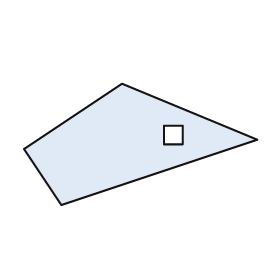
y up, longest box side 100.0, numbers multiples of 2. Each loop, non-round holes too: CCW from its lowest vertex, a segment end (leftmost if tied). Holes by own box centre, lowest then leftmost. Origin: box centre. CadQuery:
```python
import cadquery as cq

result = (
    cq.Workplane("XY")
    .moveTo(-34.0, -26.0)
    .lineTo(50.0, 2.0)
    .lineTo(-8.0, 26.0)
    .lineTo(-50.0, -2.0)
    .close()
    .moveTo(10.0, 0.0)
    .lineTo(18.0, 0.0)
    .lineTo(18.0, 8.0)
    .lineTo(10.0, 8.0)
    .close()
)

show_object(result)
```